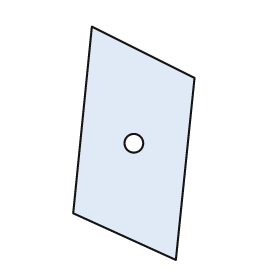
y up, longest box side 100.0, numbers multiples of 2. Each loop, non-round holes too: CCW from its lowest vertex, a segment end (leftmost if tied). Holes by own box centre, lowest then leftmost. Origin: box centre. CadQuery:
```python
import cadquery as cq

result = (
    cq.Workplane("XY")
    .moveTo(18.0, -50.0)
    .lineTo(26.0, 28.0)
    .lineTo(-18.0, 50.0)
    .lineTo(-26.0, -30.0)
    .close()
    .moveTo(0.0, 0.0)
    .circle(4.0)
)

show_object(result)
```